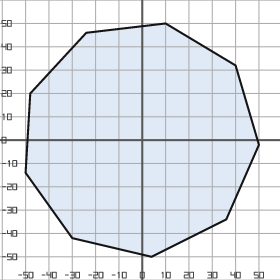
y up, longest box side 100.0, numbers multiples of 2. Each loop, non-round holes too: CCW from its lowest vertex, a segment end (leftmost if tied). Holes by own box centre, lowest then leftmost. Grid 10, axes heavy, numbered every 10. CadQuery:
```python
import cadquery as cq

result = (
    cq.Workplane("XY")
    .moveTo(4.0, -50.0)
    .lineTo(36.0, -34.0)
    .lineTo(50.0, -2.0)
    .lineTo(40.0, 32.0)
    .lineTo(10.0, 50.0)
    .lineTo(-24.0, 46.0)
    .lineTo(-48.0, 20.0)
    .lineTo(-50.0, -14.0)
    .lineTo(-30.0, -42.0)
    .close()
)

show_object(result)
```